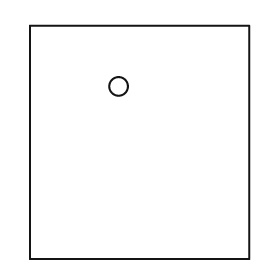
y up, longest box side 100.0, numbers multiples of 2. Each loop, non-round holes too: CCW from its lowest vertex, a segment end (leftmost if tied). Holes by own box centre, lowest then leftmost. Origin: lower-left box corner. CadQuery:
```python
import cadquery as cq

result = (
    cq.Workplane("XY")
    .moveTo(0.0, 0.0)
    .lineTo(94.0, 0.0)
    .lineTo(94.0, 100.0)
    .lineTo(0.0, 100.0)
    .close()
    .moveTo(38.0, 74.0)
    .circle(4.0)
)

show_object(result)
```